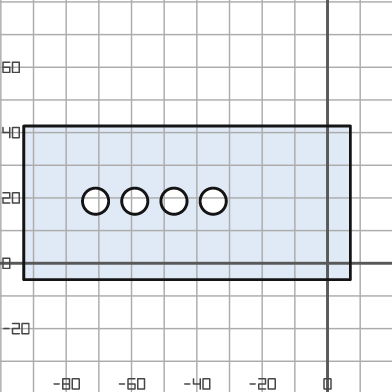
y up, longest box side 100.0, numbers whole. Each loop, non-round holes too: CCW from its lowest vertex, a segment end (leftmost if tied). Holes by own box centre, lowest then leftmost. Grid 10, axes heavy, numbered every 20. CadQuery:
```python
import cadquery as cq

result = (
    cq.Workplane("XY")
    .moveTo(-93.0, -5.0)
    .lineTo(7.0, -5.0)
    .lineTo(7.0, 42.0)
    .lineTo(-93.0, 42.0)
    .close()
    .moveTo(-71.0, 19.0)
    .circle(4.0)
    .moveTo(-59.0, 19.0)
    .circle(4.0)
    .moveTo(-47.0, 19.0)
    .circle(4.0)
    .moveTo(-35.0, 19.0)
    .circle(4.0)
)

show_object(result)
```